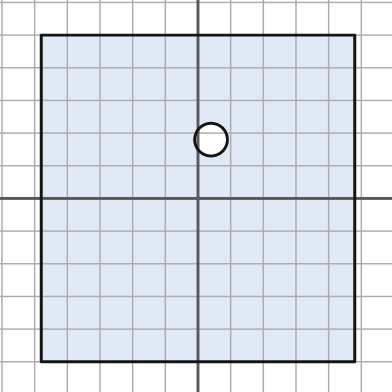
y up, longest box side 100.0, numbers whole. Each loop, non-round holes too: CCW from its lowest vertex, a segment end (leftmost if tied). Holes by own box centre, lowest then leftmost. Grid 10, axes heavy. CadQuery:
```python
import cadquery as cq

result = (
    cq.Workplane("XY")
    .moveTo(-48.0, -50.0)
    .lineTo(48.0, -50.0)
    .lineTo(48.0, 50.0)
    .lineTo(-48.0, 50.0)
    .close()
    .moveTo(4.0, 18.0)
    .circle(5.0)
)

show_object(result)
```